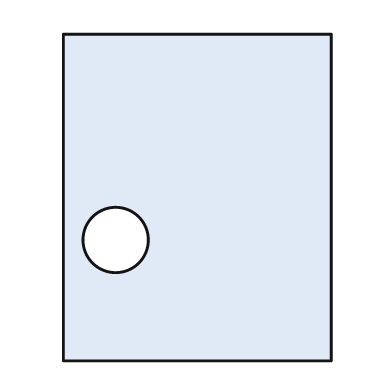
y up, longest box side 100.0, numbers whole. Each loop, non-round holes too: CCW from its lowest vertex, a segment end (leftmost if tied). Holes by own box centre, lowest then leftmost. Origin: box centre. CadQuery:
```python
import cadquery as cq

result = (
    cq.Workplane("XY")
    .moveTo(-41.0, -50.0)
    .lineTo(41.0, -50.0)
    .lineTo(41.0, 50.0)
    .lineTo(-41.0, 50.0)
    .close()
    .moveTo(-25.0, -13.0)
    .circle(10.0)
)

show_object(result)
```